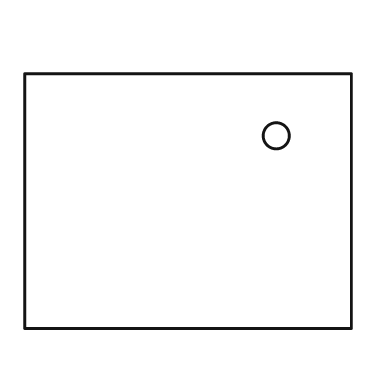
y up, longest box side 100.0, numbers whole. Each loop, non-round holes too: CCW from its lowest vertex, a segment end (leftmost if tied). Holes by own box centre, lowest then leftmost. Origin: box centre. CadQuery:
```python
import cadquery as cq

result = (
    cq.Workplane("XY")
    .moveTo(-50.0, -39.0)
    .lineTo(50.0, -39.0)
    .lineTo(50.0, 39.0)
    .lineTo(-50.0, 39.0)
    .close()
    .moveTo(27.0, 20.0)
    .circle(4.0)
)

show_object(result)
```